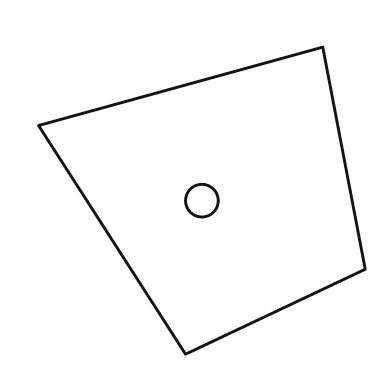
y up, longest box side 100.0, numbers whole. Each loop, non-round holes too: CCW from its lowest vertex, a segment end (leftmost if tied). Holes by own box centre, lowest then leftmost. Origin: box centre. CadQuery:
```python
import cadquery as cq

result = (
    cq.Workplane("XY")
    .moveTo(-5.0, -47.0)
    .lineTo(50.0, -21.0)
    .lineTo(37.0, 47.0)
    .lineTo(-50.0, 23.0)
    .close()
    .moveTo(0.0, 0.0)
    .circle(5.0)
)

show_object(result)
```